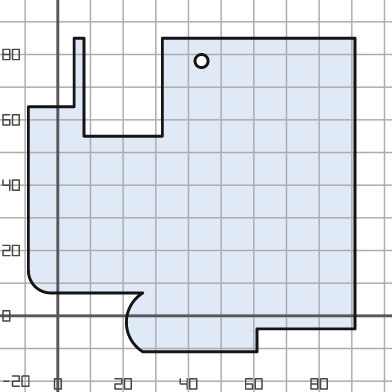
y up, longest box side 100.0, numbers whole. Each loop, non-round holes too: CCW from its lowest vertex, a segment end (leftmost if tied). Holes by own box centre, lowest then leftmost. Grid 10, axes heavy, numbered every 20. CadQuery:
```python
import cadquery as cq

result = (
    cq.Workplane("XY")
    .moveTo(26.0, -11.0)
    .lineTo(61.0, -11.0)
    .lineTo(61.0, -4.0)
    .lineTo(91.0, -4.0)
    .lineTo(91.0, 85.0)
    .lineTo(32.0, 85.0)
    .lineTo(32.0, 55.0)
    .lineTo(8.0, 55.0)
    .lineTo(8.0, 85.0)
    .lineTo(5.0, 85.0)
    .lineTo(5.0, 64.0)
    .lineTo(-9.0, 64.0)
    .lineTo(-9.0, 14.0)
    .threePointArc((-7.0, 9.0), (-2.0, 7.0))
    .lineTo(26.0, 7.0)
    .threePointArc((21.0, -2.0), (26.0, -11.0))
    .close()
    .moveTo(44.0, 78.0)
    .circle(2.0)
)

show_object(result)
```